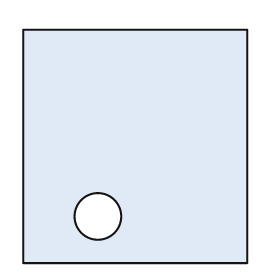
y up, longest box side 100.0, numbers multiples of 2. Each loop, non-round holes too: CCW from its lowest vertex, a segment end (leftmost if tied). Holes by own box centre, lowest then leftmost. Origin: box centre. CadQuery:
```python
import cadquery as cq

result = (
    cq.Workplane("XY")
    .moveTo(-48.0, -50.0)
    .lineTo(48.0, -50.0)
    .lineTo(48.0, 50.0)
    .lineTo(-48.0, 50.0)
    .close()
    .moveTo(-16.0, -30.0)
    .circle(10.0)
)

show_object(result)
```